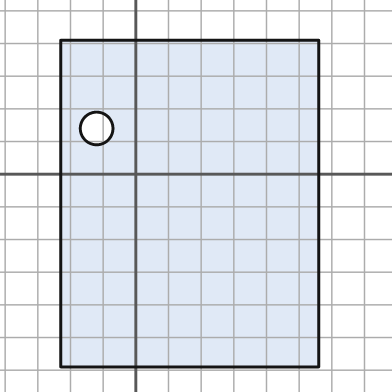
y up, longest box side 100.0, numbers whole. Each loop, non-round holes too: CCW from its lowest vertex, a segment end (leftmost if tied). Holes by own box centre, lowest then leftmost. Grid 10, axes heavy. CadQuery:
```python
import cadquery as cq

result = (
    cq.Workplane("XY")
    .moveTo(-23.0, -59.0)
    .lineTo(56.0, -59.0)
    .lineTo(56.0, 41.0)
    .lineTo(-23.0, 41.0)
    .close()
    .moveTo(-12.0, 14.0)
    .circle(5.0)
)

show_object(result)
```